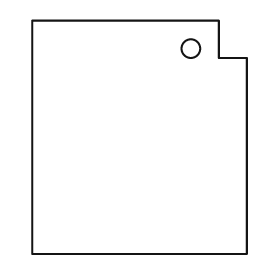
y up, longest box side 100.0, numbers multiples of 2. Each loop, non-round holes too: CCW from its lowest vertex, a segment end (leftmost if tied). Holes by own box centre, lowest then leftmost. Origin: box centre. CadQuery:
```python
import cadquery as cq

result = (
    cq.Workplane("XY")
    .moveTo(-46.0, -50.0)
    .lineTo(46.0, -50.0)
    .lineTo(46.0, 34.0)
    .lineTo(34.0, 34.0)
    .lineTo(34.0, 50.0)
    .lineTo(-46.0, 50.0)
    .close()
    .moveTo(22.0, 38.0)
    .circle(4.0)
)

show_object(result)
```